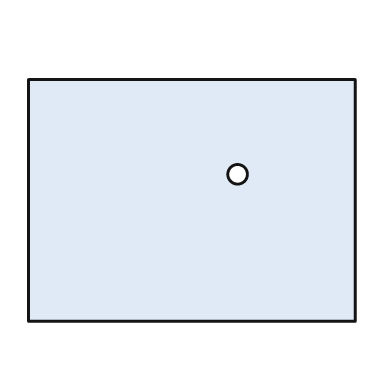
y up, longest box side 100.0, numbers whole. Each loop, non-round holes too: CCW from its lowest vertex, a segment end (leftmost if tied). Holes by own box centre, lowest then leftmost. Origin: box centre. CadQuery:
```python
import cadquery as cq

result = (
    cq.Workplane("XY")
    .moveTo(-50.0, -37.0)
    .lineTo(50.0, -37.0)
    .lineTo(50.0, 37.0)
    .lineTo(-50.0, 37.0)
    .close()
    .moveTo(14.0, 8.0)
    .circle(3.0)
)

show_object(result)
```